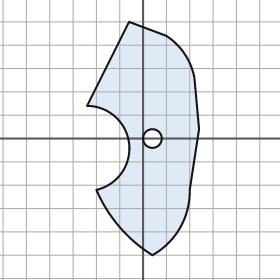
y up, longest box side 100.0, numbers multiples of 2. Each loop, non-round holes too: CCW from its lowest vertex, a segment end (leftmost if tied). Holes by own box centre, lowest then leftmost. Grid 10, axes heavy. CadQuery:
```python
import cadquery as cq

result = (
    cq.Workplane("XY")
    .moveTo(4.0, -50.0)
    .threePointArc((16.0, -38.0), (20.0, -22.0))
    .lineTo(24.0, 4.0)
    .lineTo(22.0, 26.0)
    .threePointArc((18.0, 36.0), (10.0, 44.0))
    .lineTo(-6.0, 50.0)
    .lineTo(-24.0, 14.0)
    .threePointArc((-6.0, -2.0), (-20.0, -22.0))
    .threePointArc((-10.0, -38.0), (4.0, -50.0))
    .close()
    .moveTo(4.0, 0.0)
    .circle(4.0)
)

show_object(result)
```